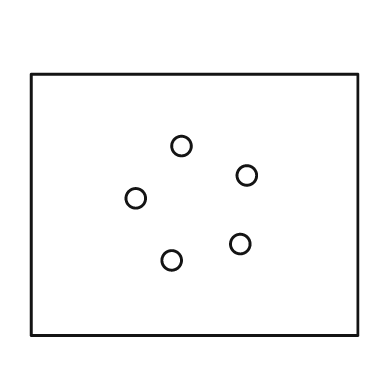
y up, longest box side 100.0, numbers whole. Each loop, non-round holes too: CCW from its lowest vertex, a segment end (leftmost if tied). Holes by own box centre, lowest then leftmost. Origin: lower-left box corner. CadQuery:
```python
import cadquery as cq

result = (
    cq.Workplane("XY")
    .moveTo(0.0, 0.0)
    .lineTo(100.0, 0.0)
    .lineTo(100.0, 80.0)
    .lineTo(0.0, 80.0)
    .close()
    .moveTo(43.0, 23.0)
    .circle(3.0)
    .moveTo(64.0, 28.0)
    .circle(3.0)
    .moveTo(32.0, 42.0)
    .circle(3.0)
    .moveTo(66.0, 49.0)
    .circle(3.0)
    .moveTo(46.0, 58.0)
    .circle(3.0)
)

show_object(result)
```